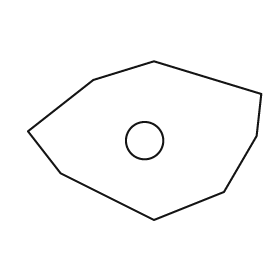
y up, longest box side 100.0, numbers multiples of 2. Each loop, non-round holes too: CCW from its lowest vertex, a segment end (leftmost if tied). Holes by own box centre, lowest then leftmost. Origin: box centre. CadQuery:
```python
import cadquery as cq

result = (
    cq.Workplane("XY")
    .moveTo(4.0, -34.0)
    .lineTo(34.0, -22.0)
    .lineTo(48.0, 2.0)
    .lineTo(50.0, 20.0)
    .lineTo(4.0, 34.0)
    .lineTo(-22.0, 26.0)
    .lineTo(-50.0, 4.0)
    .lineTo(-36.0, -14.0)
    .close()
    .moveTo(0.0, 0.0)
    .circle(8.0)
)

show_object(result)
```